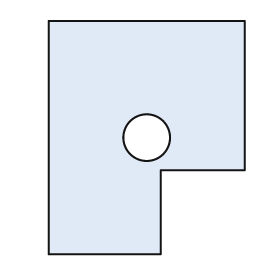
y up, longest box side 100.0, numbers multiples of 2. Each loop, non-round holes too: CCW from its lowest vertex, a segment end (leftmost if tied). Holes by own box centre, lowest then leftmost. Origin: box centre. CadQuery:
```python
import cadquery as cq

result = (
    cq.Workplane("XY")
    .moveTo(-42.0, -50.0)
    .lineTo(6.0, -50.0)
    .lineTo(6.0, -14.0)
    .lineTo(42.0, -14.0)
    .lineTo(42.0, 50.0)
    .lineTo(-42.0, 50.0)
    .close()
    .moveTo(0.0, 0.0)
    .circle(10.0)
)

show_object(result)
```